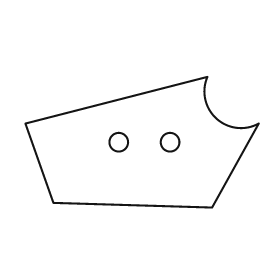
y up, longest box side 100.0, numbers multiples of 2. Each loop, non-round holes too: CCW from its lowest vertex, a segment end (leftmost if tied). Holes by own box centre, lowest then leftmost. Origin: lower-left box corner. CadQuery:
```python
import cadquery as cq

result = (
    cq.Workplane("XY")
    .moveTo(80.0, 0.0)
    .lineTo(100.0, 36.0)
    .threePointArc((82.0, 38.0), (78.0, 56.0))
    .lineTo(0.0, 36.0)
    .lineTo(12.0, 2.0)
    .close()
    .moveTo(40.0, 28.0)
    .circle(4.0)
    .moveTo(62.0, 28.0)
    .circle(4.0)
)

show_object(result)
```